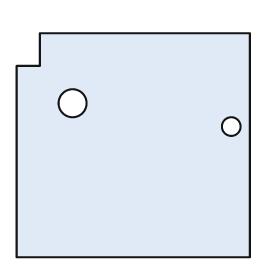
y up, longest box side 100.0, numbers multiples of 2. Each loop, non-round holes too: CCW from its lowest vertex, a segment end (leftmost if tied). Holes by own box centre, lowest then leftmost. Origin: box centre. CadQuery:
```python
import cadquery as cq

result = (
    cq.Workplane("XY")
    .moveTo(-50.0, -48.0)
    .lineTo(50.0, -48.0)
    .lineTo(50.0, 48.0)
    .lineTo(-40.0, 48.0)
    .lineTo(-40.0, 34.0)
    .lineTo(-50.0, 34.0)
    .close()
    .moveTo(42.0, 8.0)
    .circle(4.0)
    .moveTo(-26.0, 18.0)
    .circle(6.0)
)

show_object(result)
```